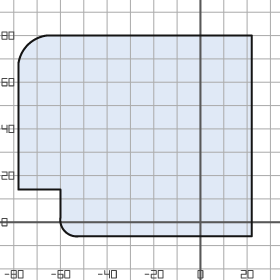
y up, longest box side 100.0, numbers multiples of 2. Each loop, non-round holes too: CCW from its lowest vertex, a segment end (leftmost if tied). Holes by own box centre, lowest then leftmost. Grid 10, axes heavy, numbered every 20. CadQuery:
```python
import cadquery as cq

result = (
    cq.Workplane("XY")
    .moveTo(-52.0, -6.0)
    .lineTo(22.0, -6.0)
    .lineTo(22.0, 80.0)
    .lineTo(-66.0, 80.0)
    .threePointArc((-74.0, 76.0), (-78.0, 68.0))
    .lineTo(-78.0, 14.0)
    .lineTo(-60.0, 14.0)
    .lineTo(-60.0, 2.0)
    .threePointArc((-58.0, -4.0), (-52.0, -6.0))
    .close()
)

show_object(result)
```